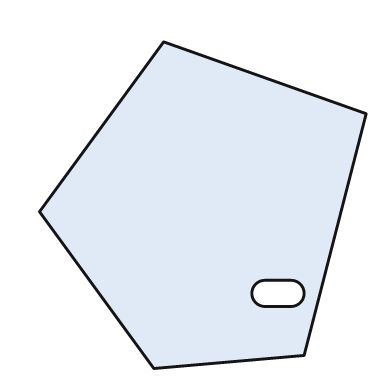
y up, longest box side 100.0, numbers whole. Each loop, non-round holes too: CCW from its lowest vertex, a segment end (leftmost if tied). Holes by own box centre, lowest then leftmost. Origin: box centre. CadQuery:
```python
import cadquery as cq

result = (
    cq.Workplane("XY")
    .moveTo(-15.0, -50.0)
    .lineTo(31.0, -46.0)
    .lineTo(50.0, 28.0)
    .lineTo(-12.0, 50.0)
    .lineTo(-50.0, -2.0)
    .close()
    .moveTo(19.0, -31.0)
    .lineTo(27.0, -31.0)
    .threePointArc((31.0, -27.0), (27.0, -23.0))
    .lineTo(19.0, -23.0)
    .threePointArc((15.0, -27.0), (19.0, -31.0))
    .close()
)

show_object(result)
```